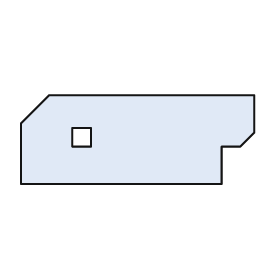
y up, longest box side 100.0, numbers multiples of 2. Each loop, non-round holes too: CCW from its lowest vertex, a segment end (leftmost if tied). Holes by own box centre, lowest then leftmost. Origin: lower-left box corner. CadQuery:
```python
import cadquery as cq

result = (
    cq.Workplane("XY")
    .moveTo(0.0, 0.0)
    .lineTo(86.0, 0.0)
    .lineTo(86.0, 16.0)
    .lineTo(94.0, 16.0)
    .lineTo(100.0, 22.0)
    .lineTo(100.0, 38.0)
    .lineTo(12.0, 38.0)
    .lineTo(0.0, 26.0)
    .close()
    .moveTo(22.0, 16.0)
    .lineTo(30.0, 16.0)
    .lineTo(30.0, 24.0)
    .lineTo(22.0, 24.0)
    .close()
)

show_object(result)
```